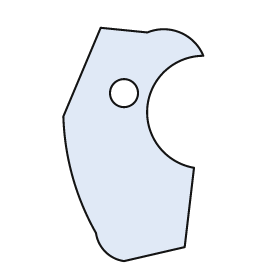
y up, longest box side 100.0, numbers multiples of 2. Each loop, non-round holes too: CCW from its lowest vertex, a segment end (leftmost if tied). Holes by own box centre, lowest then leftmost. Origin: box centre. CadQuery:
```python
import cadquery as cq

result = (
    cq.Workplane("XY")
    .moveTo(-4.0, -50.0)
    .lineTo(22.0, -44.0)
    .lineTo(26.0, -10.0)
    .threePointArc((6.0, 16.0), (30.0, 38.0))
    .threePointArc((20.0, 48.0), (6.0, 48.0))
    .lineTo(-14.0, 50.0)
    .lineTo(-30.0, 12.0)
    .threePointArc((-26.0, -14.0), (-16.0, -38.0))
    .threePointArc((-12.0, -46.0), (-4.0, -50.0))
    .close()
    .moveTo(-4.0, 22.0)
    .circle(6.0)
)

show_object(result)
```